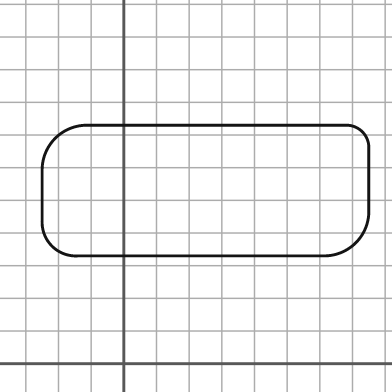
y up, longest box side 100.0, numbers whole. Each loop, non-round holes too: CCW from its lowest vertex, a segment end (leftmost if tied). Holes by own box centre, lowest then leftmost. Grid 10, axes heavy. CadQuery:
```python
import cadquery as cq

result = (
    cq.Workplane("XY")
    .moveTo(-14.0, 33.0)
    .lineTo(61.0, 33.0)
    .threePointArc((71.0, 37.0), (75.0, 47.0))
    .lineTo(75.0, 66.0)
    .threePointArc((73.0, 71.0), (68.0, 73.0))
    .lineTo(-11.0, 73.0)
    .threePointArc((-21.0, 69.0), (-25.0, 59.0))
    .lineTo(-25.0, 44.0)
    .threePointArc((-22.0, 36.0), (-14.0, 33.0))
    .close()
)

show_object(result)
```